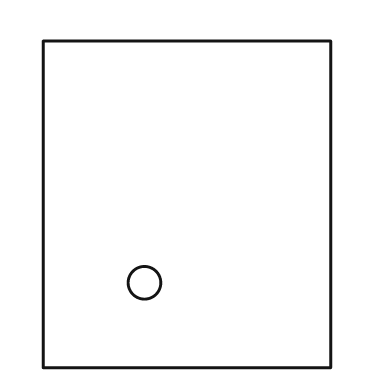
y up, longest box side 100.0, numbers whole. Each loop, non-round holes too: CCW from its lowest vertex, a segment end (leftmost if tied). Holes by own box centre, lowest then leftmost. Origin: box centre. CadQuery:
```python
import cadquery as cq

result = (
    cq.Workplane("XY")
    .moveTo(-44.0, -50.0)
    .lineTo(44.0, -50.0)
    .lineTo(44.0, 50.0)
    .lineTo(-44.0, 50.0)
    .close()
    .moveTo(-13.0, -24.0)
    .circle(5.0)
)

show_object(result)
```